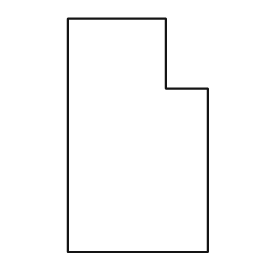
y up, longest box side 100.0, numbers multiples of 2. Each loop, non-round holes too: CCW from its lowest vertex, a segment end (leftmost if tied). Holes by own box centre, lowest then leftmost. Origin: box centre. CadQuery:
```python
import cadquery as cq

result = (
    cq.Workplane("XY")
    .moveTo(-30.0, -50.0)
    .lineTo(30.0, -50.0)
    .lineTo(30.0, 20.0)
    .lineTo(12.0, 20.0)
    .lineTo(12.0, 50.0)
    .lineTo(-30.0, 50.0)
    .close()
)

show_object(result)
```